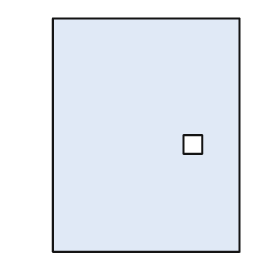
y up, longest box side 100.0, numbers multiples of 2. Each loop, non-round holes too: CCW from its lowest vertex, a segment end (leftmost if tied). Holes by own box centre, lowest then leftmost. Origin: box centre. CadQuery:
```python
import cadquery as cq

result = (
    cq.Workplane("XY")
    .moveTo(-40.0, -50.0)
    .lineTo(40.0, -50.0)
    .lineTo(40.0, 50.0)
    .lineTo(-40.0, 50.0)
    .close()
    .moveTo(16.0, -8.0)
    .lineTo(24.0, -8.0)
    .lineTo(24.0, 0.0)
    .lineTo(16.0, 0.0)
    .close()
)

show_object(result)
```